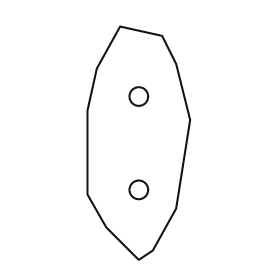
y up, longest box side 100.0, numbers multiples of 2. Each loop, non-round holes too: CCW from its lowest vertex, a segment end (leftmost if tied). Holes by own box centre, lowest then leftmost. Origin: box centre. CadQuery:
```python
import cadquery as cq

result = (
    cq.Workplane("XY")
    .moveTo(0.0, -50.0)
    .lineTo(6.0, -46.0)
    .lineTo(16.0, -28.0)
    .lineTo(22.0, 10.0)
    .lineTo(16.0, 34.0)
    .lineTo(10.0, 46.0)
    .lineTo(-8.0, 50.0)
    .lineTo(-18.0, 32.0)
    .lineTo(-22.0, 14.0)
    .lineTo(-22.0, -22.0)
    .lineTo(-14.0, -36.0)
    .close()
    .moveTo(0.0, -20.0)
    .circle(4.0)
    .moveTo(0.0, 20.0)
    .circle(4.0)
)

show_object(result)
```